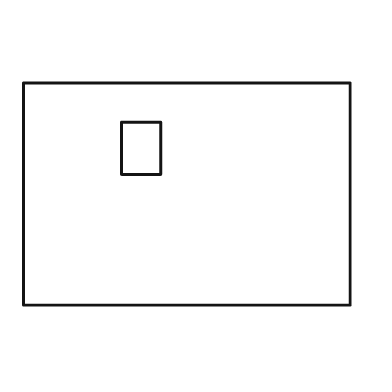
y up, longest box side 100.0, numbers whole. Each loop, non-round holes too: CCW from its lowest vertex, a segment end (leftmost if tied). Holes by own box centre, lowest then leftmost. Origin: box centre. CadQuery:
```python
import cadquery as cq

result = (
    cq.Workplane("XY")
    .moveTo(-50.0, -34.0)
    .lineTo(50.0, -34.0)
    .lineTo(50.0, 34.0)
    .lineTo(-50.0, 34.0)
    .close()
    .moveTo(-20.0, 6.0)
    .lineTo(-8.0, 6.0)
    .lineTo(-8.0, 22.0)
    .lineTo(-20.0, 22.0)
    .close()
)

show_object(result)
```